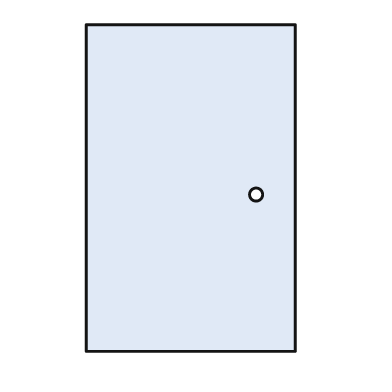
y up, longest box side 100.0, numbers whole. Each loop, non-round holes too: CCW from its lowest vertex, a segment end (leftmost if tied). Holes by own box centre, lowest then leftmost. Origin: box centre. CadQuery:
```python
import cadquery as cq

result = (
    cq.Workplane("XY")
    .moveTo(-32.0, -50.0)
    .lineTo(32.0, -50.0)
    .lineTo(32.0, 50.0)
    .lineTo(-32.0, 50.0)
    .close()
    .moveTo(20.0, -2.0)
    .circle(2.0)
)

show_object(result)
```